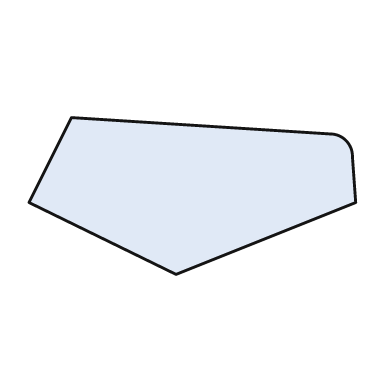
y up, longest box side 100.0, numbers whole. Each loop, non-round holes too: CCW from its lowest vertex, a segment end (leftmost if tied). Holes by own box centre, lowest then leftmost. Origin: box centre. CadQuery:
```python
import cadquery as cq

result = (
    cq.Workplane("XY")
    .moveTo(-5.0, -24.0)
    .lineTo(50.0, -2.0)
    .lineTo(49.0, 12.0)
    .threePointArc((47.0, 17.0), (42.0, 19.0))
    .lineTo(-37.0, 24.0)
    .lineTo(-50.0, -2.0)
    .close()
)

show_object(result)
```